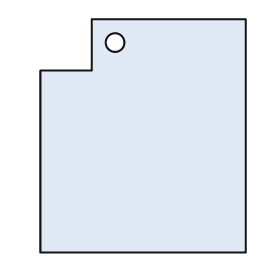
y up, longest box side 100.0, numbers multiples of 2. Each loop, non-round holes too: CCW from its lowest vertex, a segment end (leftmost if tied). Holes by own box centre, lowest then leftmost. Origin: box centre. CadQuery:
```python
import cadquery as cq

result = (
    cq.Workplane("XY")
    .moveTo(-44.0, -50.0)
    .lineTo(44.0, -50.0)
    .lineTo(44.0, 50.0)
    .lineTo(-22.0, 50.0)
    .lineTo(-22.0, 28.0)
    .lineTo(-44.0, 28.0)
    .close()
    .moveTo(-12.0, 40.0)
    .circle(4.0)
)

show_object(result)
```